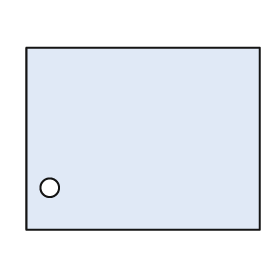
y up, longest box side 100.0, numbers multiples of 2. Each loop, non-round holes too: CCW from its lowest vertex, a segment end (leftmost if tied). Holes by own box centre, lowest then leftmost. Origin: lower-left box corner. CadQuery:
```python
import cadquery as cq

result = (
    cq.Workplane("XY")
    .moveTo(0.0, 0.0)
    .lineTo(100.0, 0.0)
    .lineTo(100.0, 78.0)
    .lineTo(0.0, 78.0)
    .close()
    .moveTo(10.0, 18.0)
    .circle(4.0)
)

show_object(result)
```